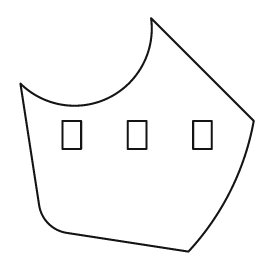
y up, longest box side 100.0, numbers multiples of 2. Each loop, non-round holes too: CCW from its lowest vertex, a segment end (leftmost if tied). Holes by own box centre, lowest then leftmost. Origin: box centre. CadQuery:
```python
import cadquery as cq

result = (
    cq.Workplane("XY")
    .moveTo(22.0, -50.0)
    .threePointArc((40.0, -24.0), (50.0, 6.0))
    .lineTo(6.0, 50.0)
    .threePointArc((-12.0, 16.0), (-50.0, 22.0))
    .lineTo(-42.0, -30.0)
    .threePointArc((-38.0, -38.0), (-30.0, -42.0))
    .close()
    .moveTo(-32.0, -6.0)
    .lineTo(-24.0, -6.0)
    .lineTo(-24.0, 6.0)
    .lineTo(-32.0, 6.0)
    .close()
    .moveTo(-4.0, -6.0)
    .lineTo(4.0, -6.0)
    .lineTo(4.0, 6.0)
    .lineTo(-4.0, 6.0)
    .close()
    .moveTo(24.0, -6.0)
    .lineTo(32.0, -6.0)
    .lineTo(32.0, 6.0)
    .lineTo(24.0, 6.0)
    .close()
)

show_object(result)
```